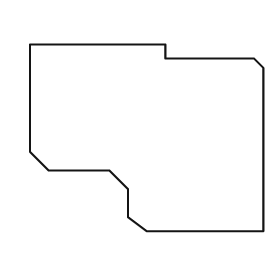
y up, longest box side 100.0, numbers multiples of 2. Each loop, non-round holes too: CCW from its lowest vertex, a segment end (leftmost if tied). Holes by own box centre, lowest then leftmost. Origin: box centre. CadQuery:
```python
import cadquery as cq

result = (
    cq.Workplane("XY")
    .moveTo(0.0, -40.0)
    .lineTo(50.0, -40.0)
    .lineTo(50.0, 30.0)
    .lineTo(46.0, 34.0)
    .lineTo(8.0, 34.0)
    .lineTo(8.0, 40.0)
    .lineTo(-50.0, 40.0)
    .lineTo(-50.0, -6.0)
    .lineTo(-42.0, -14.0)
    .lineTo(-16.0, -14.0)
    .lineTo(-8.0, -22.0)
    .lineTo(-8.0, -34.0)
    .close()
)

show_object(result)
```